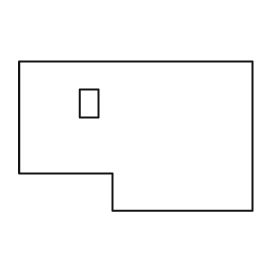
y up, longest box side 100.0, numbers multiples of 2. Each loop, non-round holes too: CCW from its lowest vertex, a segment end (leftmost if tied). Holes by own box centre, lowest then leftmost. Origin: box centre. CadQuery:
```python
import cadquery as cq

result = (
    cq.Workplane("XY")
    .moveTo(-10.0, -32.0)
    .lineTo(50.0, -32.0)
    .lineTo(50.0, 32.0)
    .lineTo(-50.0, 32.0)
    .lineTo(-50.0, -16.0)
    .lineTo(-10.0, -16.0)
    .close()
    .moveTo(-24.0, 8.0)
    .lineTo(-16.0, 8.0)
    .lineTo(-16.0, 20.0)
    .lineTo(-24.0, 20.0)
    .close()
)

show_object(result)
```